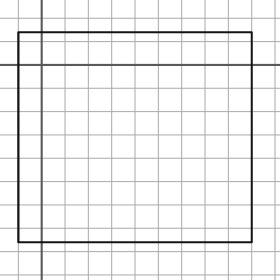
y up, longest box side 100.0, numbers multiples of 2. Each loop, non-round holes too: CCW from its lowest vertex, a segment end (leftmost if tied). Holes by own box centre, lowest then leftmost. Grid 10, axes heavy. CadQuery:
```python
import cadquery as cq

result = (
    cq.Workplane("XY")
    .moveTo(-10.0, -76.0)
    .lineTo(90.0, -76.0)
    .lineTo(90.0, 14.0)
    .lineTo(-10.0, 14.0)
    .close()
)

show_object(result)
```